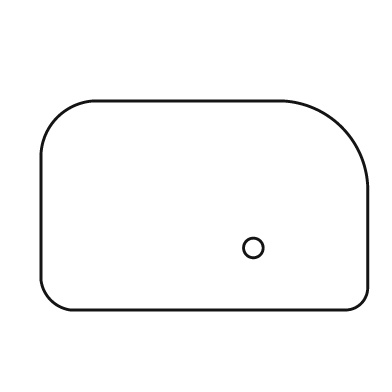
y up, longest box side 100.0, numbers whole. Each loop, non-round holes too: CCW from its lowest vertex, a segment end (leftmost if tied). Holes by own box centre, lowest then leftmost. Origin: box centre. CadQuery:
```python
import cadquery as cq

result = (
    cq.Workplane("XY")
    .moveTo(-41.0, -32.0)
    .lineTo(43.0, -32.0)
    .threePointArc((48.0, -30.0), (50.0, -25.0))
    .lineTo(50.0, 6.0)
    .threePointArc((42.0, 24.0), (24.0, 32.0))
    .lineTo(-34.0, 32.0)
    .threePointArc((-45.0, 27.0), (-50.0, 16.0))
    .lineTo(-50.0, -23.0)
    .threePointArc((-47.0, -29.0), (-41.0, -32.0))
    .close()
    .moveTo(15.0, -13.0)
    .circle(3.0)
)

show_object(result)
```